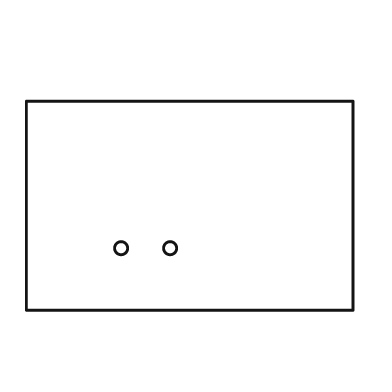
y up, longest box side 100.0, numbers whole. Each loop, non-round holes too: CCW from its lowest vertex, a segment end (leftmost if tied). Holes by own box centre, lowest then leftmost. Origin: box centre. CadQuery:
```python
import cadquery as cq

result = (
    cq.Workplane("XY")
    .moveTo(-50.0, -32.0)
    .lineTo(50.0, -32.0)
    .lineTo(50.0, 32.0)
    .lineTo(-50.0, 32.0)
    .close()
    .moveTo(-21.0, -13.0)
    .circle(2.0)
    .moveTo(-6.0, -13.0)
    .circle(2.0)
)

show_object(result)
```